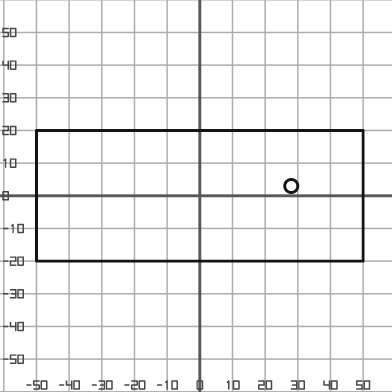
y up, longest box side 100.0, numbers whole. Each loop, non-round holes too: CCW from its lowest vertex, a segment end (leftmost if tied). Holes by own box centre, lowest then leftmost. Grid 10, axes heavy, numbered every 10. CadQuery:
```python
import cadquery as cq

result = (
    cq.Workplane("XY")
    .moveTo(-50.0, -20.0)
    .lineTo(50.0, -20.0)
    .lineTo(50.0, 20.0)
    .lineTo(-50.0, 20.0)
    .close()
    .moveTo(28.0, 3.0)
    .circle(2.0)
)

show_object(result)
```